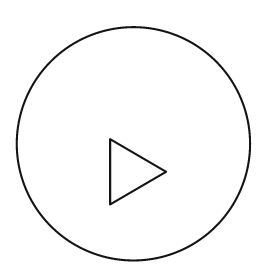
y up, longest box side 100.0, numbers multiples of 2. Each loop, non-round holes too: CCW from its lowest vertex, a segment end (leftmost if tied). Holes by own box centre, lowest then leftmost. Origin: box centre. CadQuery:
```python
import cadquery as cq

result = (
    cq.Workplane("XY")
    .moveTo(0.0, 0.0)
    .circle(50.0)
    .moveTo(-10.0, -26.0)
    .lineTo(14.0, -12.0)
    .lineTo(-10.0, 2.0)
    .close()
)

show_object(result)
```